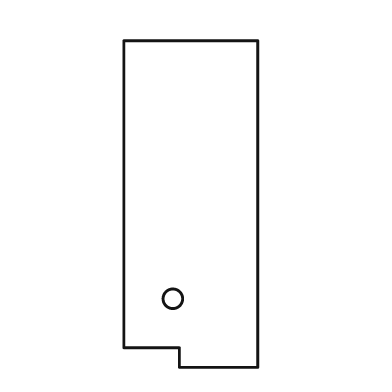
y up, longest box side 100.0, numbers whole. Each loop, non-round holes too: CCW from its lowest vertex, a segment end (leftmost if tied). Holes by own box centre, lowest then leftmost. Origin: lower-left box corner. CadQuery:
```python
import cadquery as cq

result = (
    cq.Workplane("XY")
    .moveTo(17.0, 0.0)
    .lineTo(41.0, 0.0)
    .lineTo(41.0, 100.0)
    .lineTo(0.0, 100.0)
    .lineTo(0.0, 6.0)
    .lineTo(17.0, 6.0)
    .close()
    .moveTo(15.0, 21.0)
    .circle(3.0)
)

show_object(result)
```